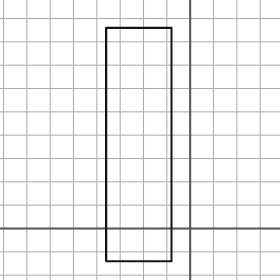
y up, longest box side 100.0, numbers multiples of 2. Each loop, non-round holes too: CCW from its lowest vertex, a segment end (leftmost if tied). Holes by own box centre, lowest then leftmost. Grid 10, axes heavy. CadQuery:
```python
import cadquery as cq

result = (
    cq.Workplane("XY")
    .moveTo(-36.0, -14.0)
    .lineTo(-8.0, -14.0)
    .lineTo(-8.0, 86.0)
    .lineTo(-36.0, 86.0)
    .close()
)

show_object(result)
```